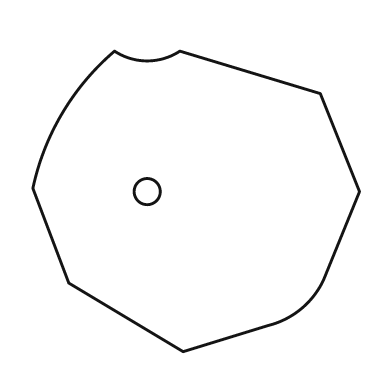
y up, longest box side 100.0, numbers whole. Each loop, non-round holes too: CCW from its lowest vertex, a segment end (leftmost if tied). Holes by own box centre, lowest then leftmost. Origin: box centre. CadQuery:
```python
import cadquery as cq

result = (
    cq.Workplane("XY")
    .moveTo(-4.0, -46.0)
    .lineTo(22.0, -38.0)
    .threePointArc((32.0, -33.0), (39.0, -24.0))
    .lineTo(50.0, 3.0)
    .lineTo(38.0, 33.0)
    .lineTo(-5.0, 46.0)
    .threePointArc((-15.0, 43.0), (-25.0, 46.0))
    .threePointArc((-41.0, 27.0), (-50.0, 4.0))
    .lineTo(-39.0, -25.0)
    .close()
    .moveTo(-15.0, 3.0)
    .circle(4.0)
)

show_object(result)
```